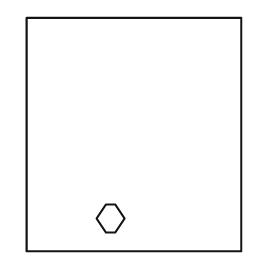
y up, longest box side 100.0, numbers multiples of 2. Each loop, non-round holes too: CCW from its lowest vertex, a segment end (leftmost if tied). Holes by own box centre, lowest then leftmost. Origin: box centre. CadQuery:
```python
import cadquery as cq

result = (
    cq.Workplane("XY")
    .moveTo(-46.0, -50.0)
    .lineTo(46.0, -50.0)
    .lineTo(46.0, 50.0)
    .lineTo(-46.0, 50.0)
    .close()
    .moveTo(-12.0, -42.0)
    .lineTo(-8.0, -42.0)
    .lineTo(-4.0, -36.0)
    .lineTo(-8.0, -30.0)
    .lineTo(-12.0, -30.0)
    .lineTo(-16.0, -36.0)
    .close()
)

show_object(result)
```